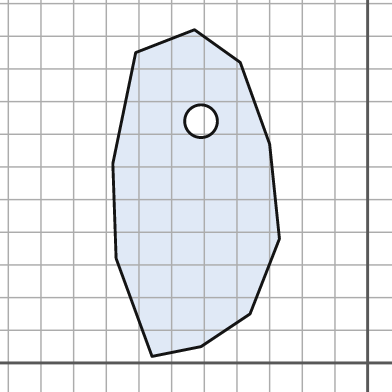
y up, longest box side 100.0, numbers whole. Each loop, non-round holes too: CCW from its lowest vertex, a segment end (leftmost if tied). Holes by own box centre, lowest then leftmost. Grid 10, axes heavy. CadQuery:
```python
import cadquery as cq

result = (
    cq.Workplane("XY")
    .moveTo(-66.0, 2.0)
    .lineTo(-51.0, 5.0)
    .lineTo(-36.0, 15.0)
    .lineTo(-27.0, 38.0)
    .lineTo(-30.0, 67.0)
    .lineTo(-39.0, 92.0)
    .lineTo(-53.0, 102.0)
    .lineTo(-71.0, 95.0)
    .lineTo(-78.0, 61.0)
    .lineTo(-77.0, 32.0)
    .close()
    .moveTo(-51.0, 74.0)
    .circle(5.0)
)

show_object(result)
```